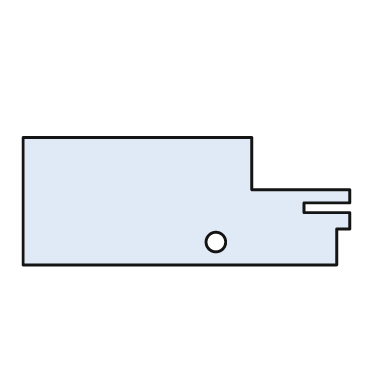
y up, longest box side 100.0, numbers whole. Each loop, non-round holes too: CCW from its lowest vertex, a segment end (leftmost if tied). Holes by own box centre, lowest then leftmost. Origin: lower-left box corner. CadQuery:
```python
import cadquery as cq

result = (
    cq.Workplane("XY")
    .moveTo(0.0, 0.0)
    .lineTo(96.0, 0.0)
    .lineTo(96.0, 11.0)
    .lineTo(100.0, 11.0)
    .lineTo(100.0, 16.0)
    .lineTo(86.0, 16.0)
    .lineTo(86.0, 19.0)
    .lineTo(100.0, 19.0)
    .lineTo(100.0, 23.0)
    .lineTo(70.0, 23.0)
    .lineTo(70.0, 39.0)
    .lineTo(0.0, 39.0)
    .close()
    .moveTo(59.0, 7.0)
    .circle(3.0)
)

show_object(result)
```